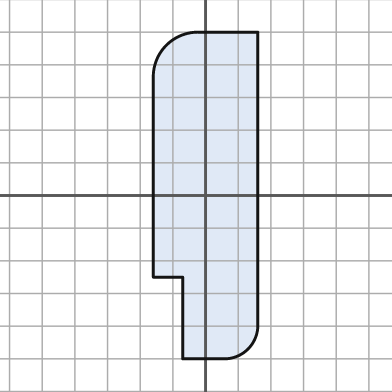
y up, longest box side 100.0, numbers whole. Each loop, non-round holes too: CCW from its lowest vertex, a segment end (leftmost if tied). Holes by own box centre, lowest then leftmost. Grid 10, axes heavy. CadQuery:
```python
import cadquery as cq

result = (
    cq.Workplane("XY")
    .moveTo(-7.0, -50.0)
    .lineTo(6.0, -50.0)
    .threePointArc((13.0, -47.0), (16.0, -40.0))
    .lineTo(16.0, 50.0)
    .lineTo(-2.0, 50.0)
    .threePointArc((-12.0, 46.0), (-16.0, 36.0))
    .lineTo(-16.0, -25.0)
    .lineTo(-7.0, -25.0)
    .close()
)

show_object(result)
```